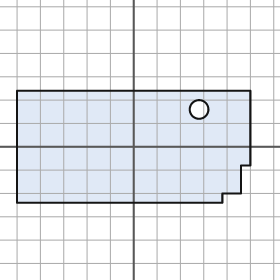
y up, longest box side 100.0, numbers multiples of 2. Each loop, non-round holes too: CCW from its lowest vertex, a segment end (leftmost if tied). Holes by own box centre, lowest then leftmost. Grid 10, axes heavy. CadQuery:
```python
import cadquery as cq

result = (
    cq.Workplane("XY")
    .moveTo(-50.0, -24.0)
    .lineTo(38.0, -24.0)
    .lineTo(38.0, -20.0)
    .lineTo(46.0, -20.0)
    .lineTo(46.0, -8.0)
    .lineTo(50.0, -8.0)
    .lineTo(50.0, 24.0)
    .lineTo(-50.0, 24.0)
    .close()
    .moveTo(28.0, 16.0)
    .circle(4.0)
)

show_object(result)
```